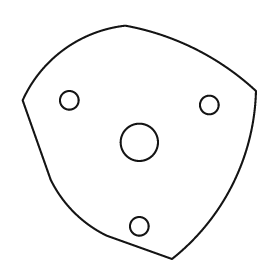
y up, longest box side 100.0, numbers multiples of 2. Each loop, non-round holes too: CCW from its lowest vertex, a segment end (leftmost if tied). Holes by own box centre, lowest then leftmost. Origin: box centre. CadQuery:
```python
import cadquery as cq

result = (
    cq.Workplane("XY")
    .moveTo(14.0, -50.0)
    .threePointArc((40.0, -18.0), (50.0, 22.0))
    .threePointArc((24.0, 40.0), (-6.0, 50.0))
    .threePointArc((-32.0, 40.0), (-50.0, 18.0))
    .lineTo(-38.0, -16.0)
    .threePointArc((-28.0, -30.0), (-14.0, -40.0))
    .close()
    .moveTo(0.0, -36.0)
    .circle(4.0)
    .moveTo(0.0, 0.0)
    .circle(8.0)
    .moveTo(30.0, 16.0)
    .circle(4.0)
    .moveTo(-30.0, 18.0)
    .circle(4.0)
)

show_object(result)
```